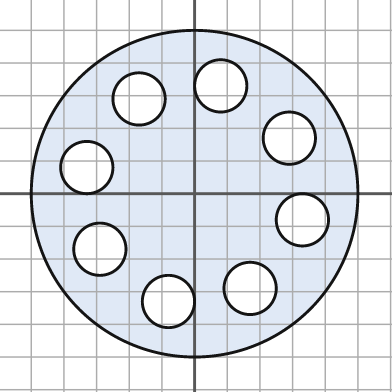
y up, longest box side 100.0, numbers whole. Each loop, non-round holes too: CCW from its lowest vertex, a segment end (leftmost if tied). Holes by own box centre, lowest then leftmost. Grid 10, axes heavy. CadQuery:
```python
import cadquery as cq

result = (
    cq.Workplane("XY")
    .moveTo(0.0, 0.0)
    .circle(50.0)
    .moveTo(-8.0, -33.0)
    .circle(8.0)
    .moveTo(17.0, -29.0)
    .circle(8.0)
    .moveTo(-29.0, -17.0)
    .circle(8.0)
    .moveTo(33.0, -8.0)
    .circle(8.0)
    .moveTo(-33.0, 8.0)
    .circle(8.0)
    .moveTo(29.0, 17.0)
    .circle(8.0)
    .moveTo(-17.0, 29.0)
    .circle(8.0)
    .moveTo(8.0, 33.0)
    .circle(8.0)
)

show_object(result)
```